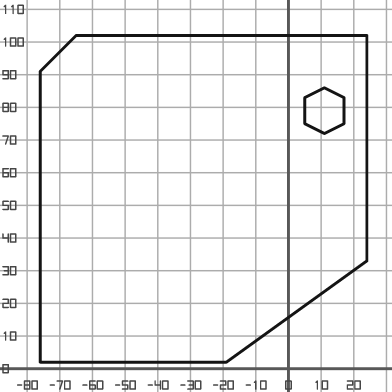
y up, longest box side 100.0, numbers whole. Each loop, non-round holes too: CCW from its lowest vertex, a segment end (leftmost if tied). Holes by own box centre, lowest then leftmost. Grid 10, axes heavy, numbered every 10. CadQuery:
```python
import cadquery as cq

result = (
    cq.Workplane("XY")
    .moveTo(-76.0, 2.0)
    .lineTo(-19.0, 2.0)
    .lineTo(24.0, 33.0)
    .lineTo(24.0, 102.0)
    .lineTo(-65.0, 102.0)
    .lineTo(-76.0, 91.0)
    .close()
    .moveTo(11.0, 72.0)
    .lineTo(17.0, 75.0)
    .lineTo(17.0, 83.0)
    .lineTo(11.0, 86.0)
    .lineTo(5.0, 83.0)
    .lineTo(5.0, 75.0)
    .close()
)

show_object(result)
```